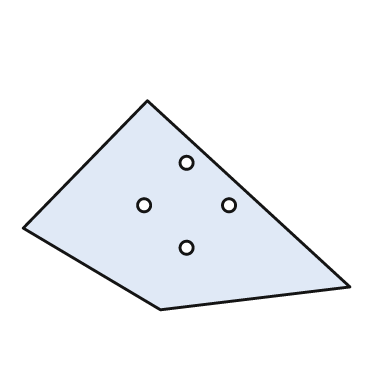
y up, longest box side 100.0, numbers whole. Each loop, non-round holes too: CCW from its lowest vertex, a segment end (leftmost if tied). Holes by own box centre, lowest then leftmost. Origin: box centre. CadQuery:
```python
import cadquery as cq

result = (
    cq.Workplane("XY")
    .moveTo(-8.0, -32.0)
    .lineTo(50.0, -25.0)
    .lineTo(-12.0, 32.0)
    .lineTo(-50.0, -7.0)
    .close()
    .moveTo(0.0, -13.0)
    .circle(2.0)
    .moveTo(-13.0, 0.0)
    .circle(2.0)
    .moveTo(13.0, 0.0)
    .circle(2.0)
    .moveTo(0.0, 13.0)
    .circle(2.0)
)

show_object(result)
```